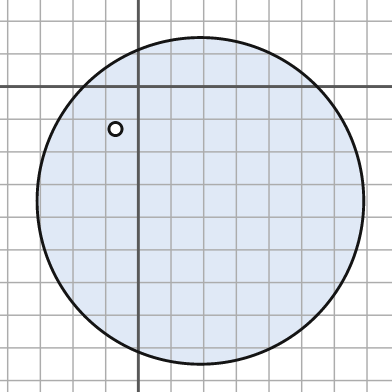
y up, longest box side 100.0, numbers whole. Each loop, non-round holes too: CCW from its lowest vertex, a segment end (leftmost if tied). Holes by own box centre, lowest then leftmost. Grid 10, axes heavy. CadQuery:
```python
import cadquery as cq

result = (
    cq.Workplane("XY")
    .moveTo(19.0, -35.0)
    .circle(50.0)
    .moveTo(-7.0, -13.0)
    .circle(2.0)
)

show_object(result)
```